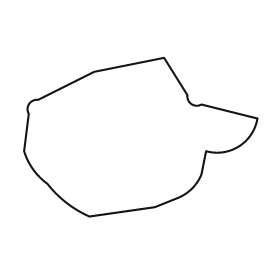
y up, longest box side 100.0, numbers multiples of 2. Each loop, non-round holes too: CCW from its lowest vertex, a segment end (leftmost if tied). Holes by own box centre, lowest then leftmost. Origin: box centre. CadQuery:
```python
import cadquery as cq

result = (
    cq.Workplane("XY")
    .moveTo(-22.0, -34.0)
    .lineTo(6.0, -30.0)
    .lineTo(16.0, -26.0)
    .threePointArc((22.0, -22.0), (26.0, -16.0))
    .lineTo(28.0, -6.0)
    .threePointArc((42.0, -4.0), (50.0, 8.0))
    .lineTo(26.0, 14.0)
    .threePointArc((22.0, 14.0), (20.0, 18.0))
    .lineTo(10.0, 34.0)
    .lineTo(-20.0, 28.0)
    .lineTo(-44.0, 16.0)
    .threePointArc((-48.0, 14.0), (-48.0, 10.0))
    .lineTo(-50.0, -6.0)
    .threePointArc((-46.0, -14.0), (-40.0, -20.0))
    .threePointArc((-32.0, -28.0), (-22.0, -34.0))
    .close()
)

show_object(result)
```